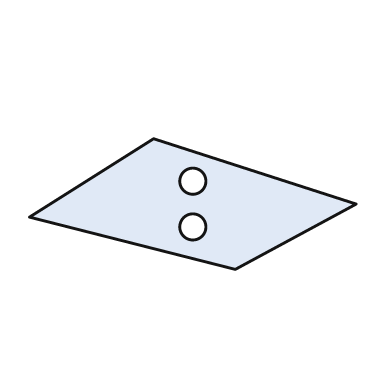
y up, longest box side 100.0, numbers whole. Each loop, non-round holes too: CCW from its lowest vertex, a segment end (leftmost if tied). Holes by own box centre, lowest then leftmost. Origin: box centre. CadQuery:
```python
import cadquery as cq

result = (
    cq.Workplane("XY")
    .moveTo(13.0, -20.0)
    .lineTo(50.0, 0.0)
    .lineTo(-12.0, 20.0)
    .lineTo(-50.0, -4.0)
    .close()
    .moveTo(0.0, -7.0)
    .circle(4.0)
    .moveTo(0.0, 7.0)
    .circle(4.0)
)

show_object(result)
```